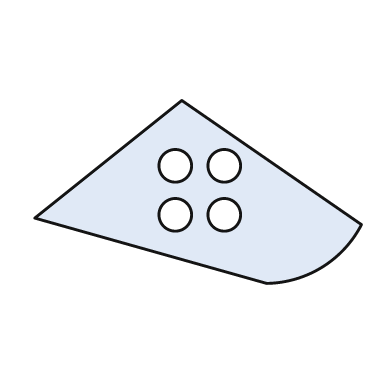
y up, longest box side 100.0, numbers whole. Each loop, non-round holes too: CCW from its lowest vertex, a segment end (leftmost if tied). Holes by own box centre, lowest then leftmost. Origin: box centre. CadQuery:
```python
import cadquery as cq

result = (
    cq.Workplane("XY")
    .moveTo(21.0, -28.0)
    .threePointArc((38.0, -23.0), (50.0, -10.0))
    .lineTo(-5.0, 28.0)
    .lineTo(-50.0, -8.0)
    .close()
    .moveTo(-7.0, -7.0)
    .circle(5.0)
    .moveTo(8.0, -7.0)
    .circle(5.0)
    .moveTo(-7.0, 8.0)
    .circle(5.0)
    .moveTo(8.0, 8.0)
    .circle(5.0)
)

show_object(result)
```